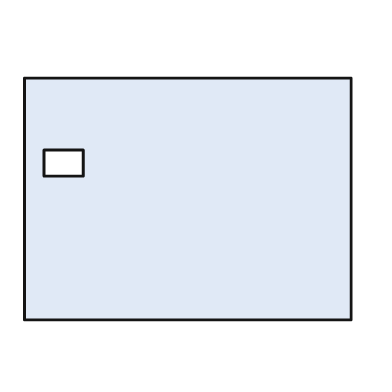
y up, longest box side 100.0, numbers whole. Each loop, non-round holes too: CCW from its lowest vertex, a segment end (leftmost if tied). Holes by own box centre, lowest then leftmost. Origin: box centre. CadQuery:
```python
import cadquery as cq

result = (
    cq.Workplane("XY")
    .moveTo(-50.0, -37.0)
    .lineTo(50.0, -37.0)
    .lineTo(50.0, 37.0)
    .lineTo(-50.0, 37.0)
    .close()
    .moveTo(-44.0, 7.0)
    .lineTo(-32.0, 7.0)
    .lineTo(-32.0, 15.0)
    .lineTo(-44.0, 15.0)
    .close()
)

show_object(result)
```